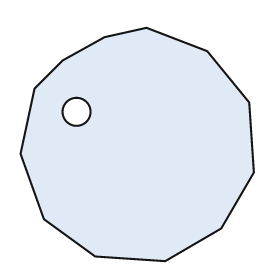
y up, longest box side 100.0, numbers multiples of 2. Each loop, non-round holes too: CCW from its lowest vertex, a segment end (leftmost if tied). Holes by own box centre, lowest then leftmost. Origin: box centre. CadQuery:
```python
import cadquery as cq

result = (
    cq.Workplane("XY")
    .moveTo(12.0, -50.0)
    .lineTo(36.0, -36.0)
    .lineTo(50.0, -12.0)
    .lineTo(48.0, 18.0)
    .lineTo(30.0, 40.0)
    .lineTo(4.0, 50.0)
    .lineTo(-14.0, 46.0)
    .lineTo(-32.0, 36.0)
    .lineTo(-44.0, 24.0)
    .lineTo(-50.0, -4.0)
    .lineTo(-40.0, -32.0)
    .lineTo(-18.0, -48.0)
    .close()
    .moveTo(-26.0, 14.0)
    .circle(6.0)
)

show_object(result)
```